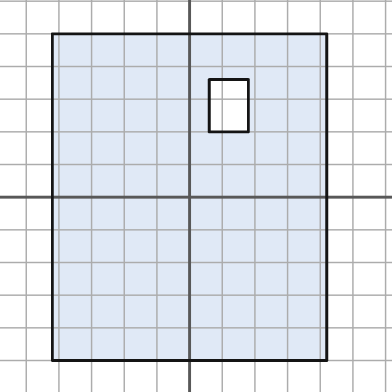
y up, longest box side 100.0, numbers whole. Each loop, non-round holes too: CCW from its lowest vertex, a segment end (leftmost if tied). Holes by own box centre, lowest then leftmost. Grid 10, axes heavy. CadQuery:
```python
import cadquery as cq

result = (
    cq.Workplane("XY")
    .moveTo(-42.0, -50.0)
    .lineTo(42.0, -50.0)
    .lineTo(42.0, 50.0)
    .lineTo(-42.0, 50.0)
    .close()
    .moveTo(6.0, 20.0)
    .lineTo(18.0, 20.0)
    .lineTo(18.0, 36.0)
    .lineTo(6.0, 36.0)
    .close()
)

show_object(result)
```